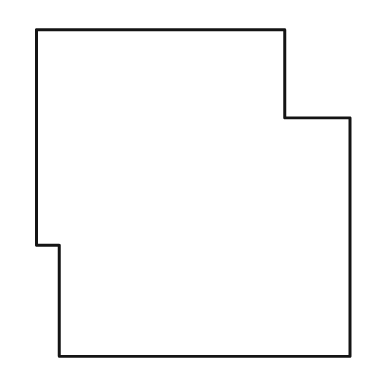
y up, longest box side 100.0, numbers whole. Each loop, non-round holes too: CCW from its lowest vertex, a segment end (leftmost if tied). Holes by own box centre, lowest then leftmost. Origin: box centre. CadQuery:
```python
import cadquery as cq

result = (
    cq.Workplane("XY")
    .moveTo(-41.0, -50.0)
    .lineTo(48.0, -50.0)
    .lineTo(48.0, 23.0)
    .lineTo(28.0, 23.0)
    .lineTo(28.0, 50.0)
    .lineTo(-48.0, 50.0)
    .lineTo(-48.0, -16.0)
    .lineTo(-41.0, -16.0)
    .close()
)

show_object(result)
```